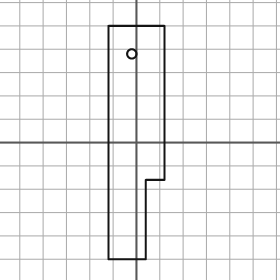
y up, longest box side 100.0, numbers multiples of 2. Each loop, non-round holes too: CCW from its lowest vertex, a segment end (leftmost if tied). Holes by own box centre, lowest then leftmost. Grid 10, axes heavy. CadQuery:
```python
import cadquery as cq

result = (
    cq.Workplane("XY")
    .moveTo(-12.0, -50.0)
    .lineTo(4.0, -50.0)
    .lineTo(4.0, -16.0)
    .lineTo(12.0, -16.0)
    .lineTo(12.0, 50.0)
    .lineTo(-12.0, 50.0)
    .close()
    .moveTo(-2.0, 38.0)
    .circle(2.0)
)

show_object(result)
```